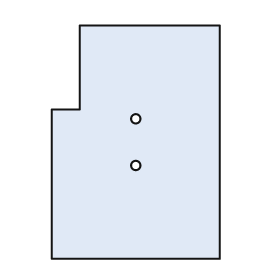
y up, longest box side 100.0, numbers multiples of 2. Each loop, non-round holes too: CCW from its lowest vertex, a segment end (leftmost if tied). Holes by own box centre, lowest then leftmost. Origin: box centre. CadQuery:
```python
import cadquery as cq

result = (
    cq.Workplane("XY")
    .moveTo(-36.0, -50.0)
    .lineTo(36.0, -50.0)
    .lineTo(36.0, 50.0)
    .lineTo(-24.0, 50.0)
    .lineTo(-24.0, 14.0)
    .lineTo(-36.0, 14.0)
    .close()
    .moveTo(0.0, -10.0)
    .circle(2.0)
    .moveTo(0.0, 10.0)
    .circle(2.0)
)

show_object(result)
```